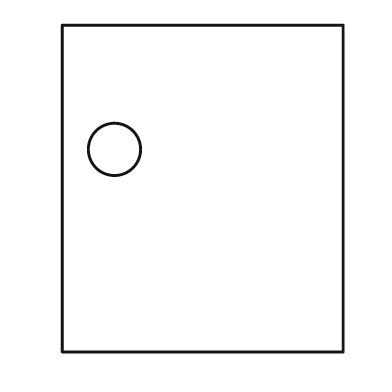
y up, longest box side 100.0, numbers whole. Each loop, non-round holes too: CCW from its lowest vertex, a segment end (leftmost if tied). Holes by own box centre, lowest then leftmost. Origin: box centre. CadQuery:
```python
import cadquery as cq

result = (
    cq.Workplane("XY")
    .moveTo(-43.0, -50.0)
    .lineTo(43.0, -50.0)
    .lineTo(43.0, 50.0)
    .lineTo(-43.0, 50.0)
    .close()
    .moveTo(-27.0, 12.0)
    .circle(8.0)
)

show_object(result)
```